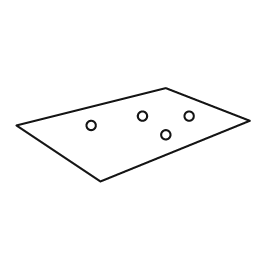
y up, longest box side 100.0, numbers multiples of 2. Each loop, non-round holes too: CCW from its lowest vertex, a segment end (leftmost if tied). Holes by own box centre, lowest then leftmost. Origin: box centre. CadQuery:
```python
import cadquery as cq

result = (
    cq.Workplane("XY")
    .moveTo(-14.0, -20.0)
    .lineTo(50.0, 6.0)
    .lineTo(14.0, 20.0)
    .lineTo(-50.0, 4.0)
    .close()
    .moveTo(14.0, 0.0)
    .circle(2.0)
    .moveTo(-18.0, 4.0)
    .circle(2.0)
    .moveTo(4.0, 8.0)
    .circle(2.0)
    .moveTo(24.0, 8.0)
    .circle(2.0)
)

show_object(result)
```